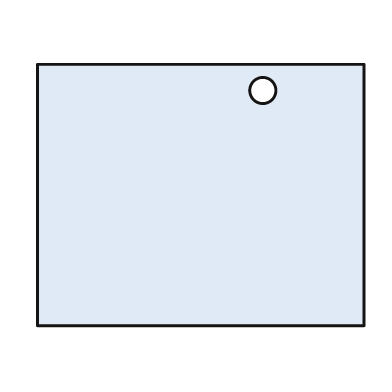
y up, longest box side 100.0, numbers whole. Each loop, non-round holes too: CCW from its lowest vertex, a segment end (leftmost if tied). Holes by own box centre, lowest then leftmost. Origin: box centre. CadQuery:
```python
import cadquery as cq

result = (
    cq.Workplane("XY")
    .moveTo(-50.0, -40.0)
    .lineTo(50.0, -40.0)
    .lineTo(50.0, 40.0)
    .lineTo(-50.0, 40.0)
    .close()
    .moveTo(19.0, 32.0)
    .circle(4.0)
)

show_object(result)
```